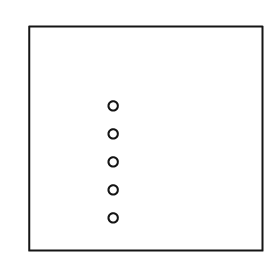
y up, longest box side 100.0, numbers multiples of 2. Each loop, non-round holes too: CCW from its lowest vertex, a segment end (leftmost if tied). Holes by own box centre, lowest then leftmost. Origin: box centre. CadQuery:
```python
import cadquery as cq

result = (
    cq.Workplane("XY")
    .moveTo(-50.0, -48.0)
    .lineTo(50.0, -48.0)
    .lineTo(50.0, 48.0)
    .lineTo(-50.0, 48.0)
    .close()
    .moveTo(-14.0, -34.0)
    .circle(2.0)
    .moveTo(-14.0, -22.0)
    .circle(2.0)
    .moveTo(-14.0, -10.0)
    .circle(2.0)
    .moveTo(-14.0, 2.0)
    .circle(2.0)
    .moveTo(-14.0, 14.0)
    .circle(2.0)
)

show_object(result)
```